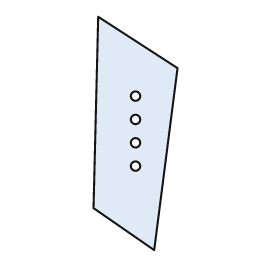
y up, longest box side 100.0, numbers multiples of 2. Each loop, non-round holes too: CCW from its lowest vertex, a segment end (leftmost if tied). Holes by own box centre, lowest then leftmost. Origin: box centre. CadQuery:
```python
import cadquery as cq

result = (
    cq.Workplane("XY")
    .moveTo(8.0, -50.0)
    .lineTo(18.0, 28.0)
    .lineTo(-16.0, 50.0)
    .lineTo(-18.0, -32.0)
    .close()
    .moveTo(0.0, -14.0)
    .circle(2.0)
    .moveTo(0.0, -4.0)
    .circle(2.0)
    .moveTo(0.0, 6.0)
    .circle(2.0)
    .moveTo(0.0, 16.0)
    .circle(2.0)
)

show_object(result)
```